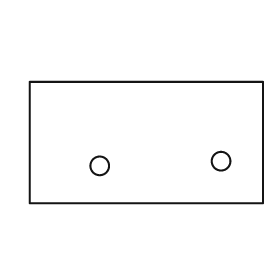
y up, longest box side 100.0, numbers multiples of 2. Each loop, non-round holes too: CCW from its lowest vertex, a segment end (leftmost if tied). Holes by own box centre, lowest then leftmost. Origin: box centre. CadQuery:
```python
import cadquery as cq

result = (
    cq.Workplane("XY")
    .moveTo(-50.0, -26.0)
    .lineTo(50.0, -26.0)
    .lineTo(50.0, 26.0)
    .lineTo(-50.0, 26.0)
    .close()
    .moveTo(-20.0, -10.0)
    .circle(4.0)
    .moveTo(32.0, -8.0)
    .circle(4.0)
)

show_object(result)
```